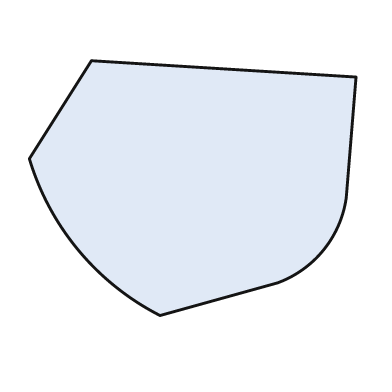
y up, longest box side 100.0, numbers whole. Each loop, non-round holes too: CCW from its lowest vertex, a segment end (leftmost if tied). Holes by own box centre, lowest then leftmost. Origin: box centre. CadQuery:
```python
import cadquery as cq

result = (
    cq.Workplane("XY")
    .moveTo(-10.0, -39.0)
    .lineTo(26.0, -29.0)
    .threePointArc((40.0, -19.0), (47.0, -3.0))
    .lineTo(50.0, 34.0)
    .lineTo(-31.0, 39.0)
    .lineTo(-50.0, 9.0)
    .threePointArc((-35.0, -19.0), (-10.0, -39.0))
    .close()
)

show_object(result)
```